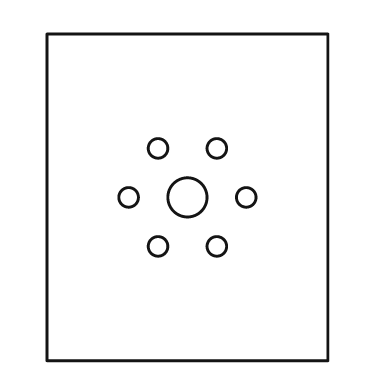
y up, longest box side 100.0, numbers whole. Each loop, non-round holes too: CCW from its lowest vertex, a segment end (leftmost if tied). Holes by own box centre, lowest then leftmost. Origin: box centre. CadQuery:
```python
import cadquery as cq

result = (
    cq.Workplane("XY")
    .moveTo(-43.0, -50.0)
    .lineTo(43.0, -50.0)
    .lineTo(43.0, 50.0)
    .lineTo(-43.0, 50.0)
    .close()
    .moveTo(-9.0, -15.0)
    .circle(3.0)
    .moveTo(9.0, -15.0)
    .circle(3.0)
    .moveTo(-18.0, 0.0)
    .circle(3.0)
    .moveTo(0.0, 0.0)
    .circle(6.0)
    .moveTo(18.0, 0.0)
    .circle(3.0)
    .moveTo(-9.0, 15.0)
    .circle(3.0)
    .moveTo(9.0, 15.0)
    .circle(3.0)
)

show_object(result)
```